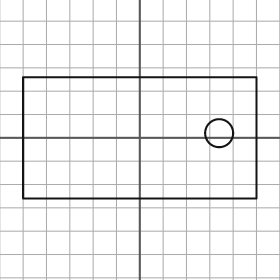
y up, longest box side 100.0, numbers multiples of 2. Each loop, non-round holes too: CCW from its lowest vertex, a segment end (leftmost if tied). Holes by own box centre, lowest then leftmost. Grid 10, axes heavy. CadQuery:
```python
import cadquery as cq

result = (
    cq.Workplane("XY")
    .moveTo(-50.0, -26.0)
    .lineTo(50.0, -26.0)
    .lineTo(50.0, 26.0)
    .lineTo(-50.0, 26.0)
    .close()
    .moveTo(34.0, 2.0)
    .circle(6.0)
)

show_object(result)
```